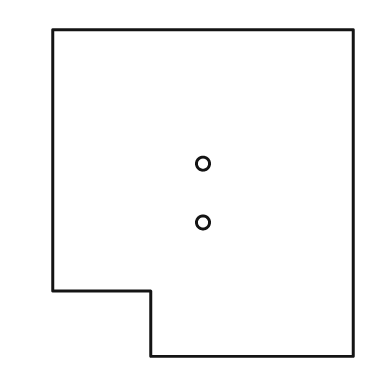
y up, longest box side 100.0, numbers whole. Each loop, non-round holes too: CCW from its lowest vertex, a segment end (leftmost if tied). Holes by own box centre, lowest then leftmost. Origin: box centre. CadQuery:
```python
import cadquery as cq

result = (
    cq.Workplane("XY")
    .moveTo(-16.0, -50.0)
    .lineTo(46.0, -50.0)
    .lineTo(46.0, 50.0)
    .lineTo(-46.0, 50.0)
    .lineTo(-46.0, -30.0)
    .lineTo(-16.0, -30.0)
    .close()
    .moveTo(0.0, -9.0)
    .circle(2.0)
    .moveTo(0.0, 9.0)
    .circle(2.0)
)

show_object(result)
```